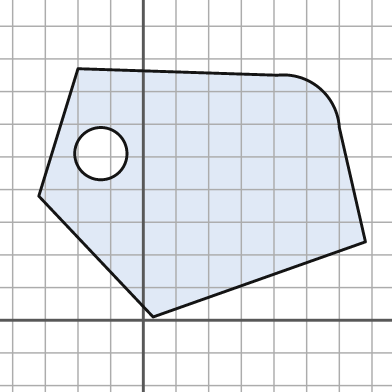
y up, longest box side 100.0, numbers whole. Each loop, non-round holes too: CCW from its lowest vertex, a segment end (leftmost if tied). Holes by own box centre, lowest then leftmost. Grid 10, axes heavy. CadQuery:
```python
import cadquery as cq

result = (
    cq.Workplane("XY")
    .moveTo(3.0, 1.0)
    .lineTo(68.0, 24.0)
    .lineTo(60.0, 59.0)
    .threePointArc((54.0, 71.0), (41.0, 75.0))
    .lineTo(-20.0, 77.0)
    .lineTo(-32.0, 38.0)
    .close()
    .moveTo(-13.0, 51.0)
    .circle(8.0)
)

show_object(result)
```